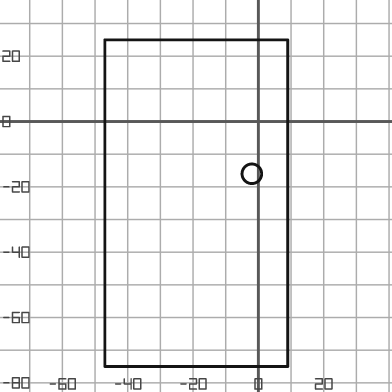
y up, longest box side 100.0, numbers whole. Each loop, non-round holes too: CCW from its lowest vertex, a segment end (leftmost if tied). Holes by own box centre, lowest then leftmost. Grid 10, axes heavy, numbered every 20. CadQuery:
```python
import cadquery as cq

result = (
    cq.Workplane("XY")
    .moveTo(-47.0, -75.0)
    .lineTo(9.0, -75.0)
    .lineTo(9.0, 25.0)
    .lineTo(-47.0, 25.0)
    .close()
    .moveTo(-2.0, -16.0)
    .circle(3.0)
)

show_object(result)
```